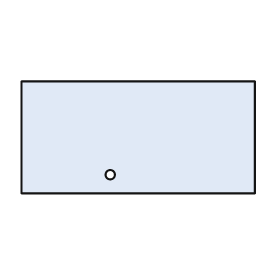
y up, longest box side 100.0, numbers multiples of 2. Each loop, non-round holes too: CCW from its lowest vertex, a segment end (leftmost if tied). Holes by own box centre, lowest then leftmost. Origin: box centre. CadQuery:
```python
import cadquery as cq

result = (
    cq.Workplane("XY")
    .moveTo(-50.0, -24.0)
    .lineTo(50.0, -24.0)
    .lineTo(50.0, 24.0)
    .lineTo(-50.0, 24.0)
    .close()
    .moveTo(-12.0, -16.0)
    .circle(2.0)
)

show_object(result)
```